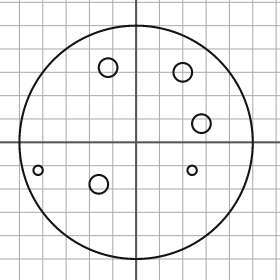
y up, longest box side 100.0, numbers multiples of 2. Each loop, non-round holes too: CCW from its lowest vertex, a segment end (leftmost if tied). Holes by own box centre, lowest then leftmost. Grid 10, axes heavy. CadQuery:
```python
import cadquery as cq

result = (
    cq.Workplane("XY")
    .moveTo(0.0, 0.0)
    .circle(50.0)
    .moveTo(-16.0, -18.0)
    .circle(4.0)
    .moveTo(-42.0, -12.0)
    .circle(2.0)
    .moveTo(24.0, -12.0)
    .circle(2.0)
    .moveTo(28.0, 8.0)
    .circle(4.0)
    .moveTo(20.0, 30.0)
    .circle(4.0)
    .moveTo(-12.0, 32.0)
    .circle(4.0)
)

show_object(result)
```